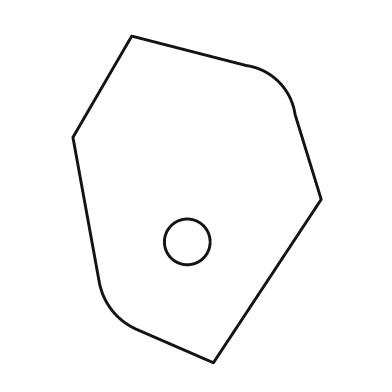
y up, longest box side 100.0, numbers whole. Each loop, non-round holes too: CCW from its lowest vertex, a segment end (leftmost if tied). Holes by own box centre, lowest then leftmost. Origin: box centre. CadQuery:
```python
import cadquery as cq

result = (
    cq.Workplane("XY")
    .moveTo(5.0, -50.0)
    .lineTo(38.0, 0.0)
    .lineTo(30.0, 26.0)
    .threePointArc((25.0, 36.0), (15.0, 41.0))
    .lineTo(-20.0, 50.0)
    .lineTo(-38.0, 19.0)
    .lineTo(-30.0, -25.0)
    .threePointArc((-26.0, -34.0), (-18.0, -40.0))
    .close()
    .moveTo(-3.0, -13.0)
    .circle(7.0)
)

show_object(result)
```